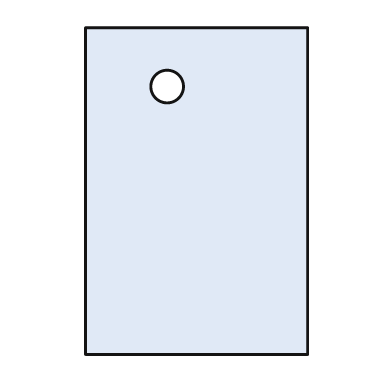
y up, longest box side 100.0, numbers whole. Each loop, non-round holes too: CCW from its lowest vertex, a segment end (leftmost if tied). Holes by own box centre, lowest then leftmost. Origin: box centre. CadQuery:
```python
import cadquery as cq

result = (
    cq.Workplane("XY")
    .moveTo(-34.0, -50.0)
    .lineTo(34.0, -50.0)
    .lineTo(34.0, 50.0)
    .lineTo(-34.0, 50.0)
    .close()
    .moveTo(-9.0, 32.0)
    .circle(5.0)
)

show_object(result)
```